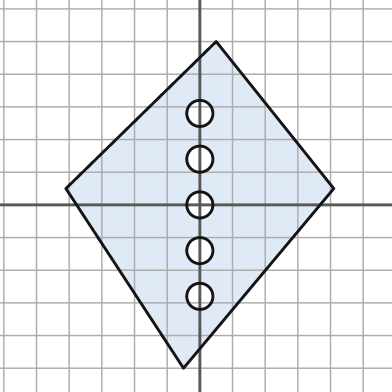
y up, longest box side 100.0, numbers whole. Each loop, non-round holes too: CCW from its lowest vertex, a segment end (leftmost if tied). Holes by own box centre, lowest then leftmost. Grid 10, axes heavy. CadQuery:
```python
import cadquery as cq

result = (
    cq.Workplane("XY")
    .moveTo(-5.0, -50.0)
    .lineTo(41.0, 5.0)
    .lineTo(5.0, 50.0)
    .lineTo(-41.0, 5.0)
    .close()
    .moveTo(0.0, -28.0)
    .circle(4.0)
    .moveTo(0.0, -14.0)
    .circle(4.0)
    .moveTo(0.0, 0.0)
    .circle(4.0)
    .moveTo(0.0, 14.0)
    .circle(4.0)
    .moveTo(0.0, 28.0)
    .circle(4.0)
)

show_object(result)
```